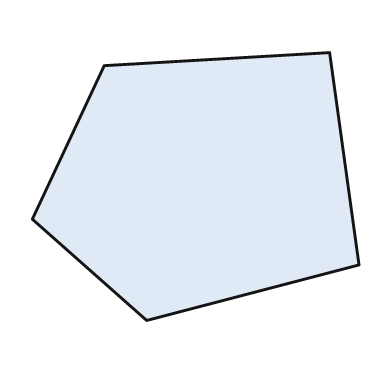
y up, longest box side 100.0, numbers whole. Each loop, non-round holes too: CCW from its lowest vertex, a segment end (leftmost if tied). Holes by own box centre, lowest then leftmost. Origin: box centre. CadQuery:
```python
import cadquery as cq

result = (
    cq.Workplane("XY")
    .moveTo(-15.0, -41.0)
    .lineTo(50.0, -24.0)
    .lineTo(41.0, 41.0)
    .lineTo(-28.0, 37.0)
    .lineTo(-50.0, -10.0)
    .close()
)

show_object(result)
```